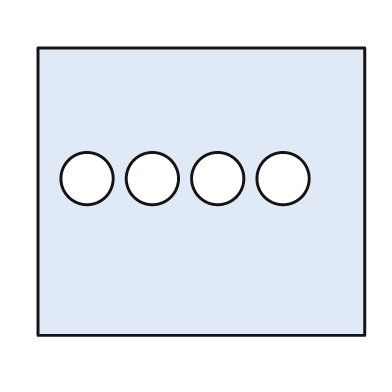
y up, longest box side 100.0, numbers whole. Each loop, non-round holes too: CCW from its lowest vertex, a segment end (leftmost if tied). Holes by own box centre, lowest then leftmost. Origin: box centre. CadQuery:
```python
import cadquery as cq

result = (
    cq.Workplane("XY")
    .moveTo(-50.0, -44.0)
    .lineTo(50.0, -44.0)
    .lineTo(50.0, 44.0)
    .lineTo(-50.0, 44.0)
    .close()
    .moveTo(-35.0, 4.0)
    .circle(8.0)
    .moveTo(-15.0, 4.0)
    .circle(8.0)
    .moveTo(5.0, 4.0)
    .circle(8.0)
    .moveTo(25.0, 4.0)
    .circle(8.0)
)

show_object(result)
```